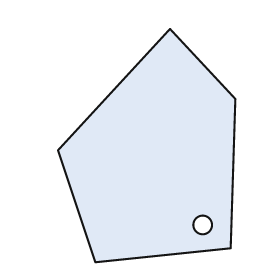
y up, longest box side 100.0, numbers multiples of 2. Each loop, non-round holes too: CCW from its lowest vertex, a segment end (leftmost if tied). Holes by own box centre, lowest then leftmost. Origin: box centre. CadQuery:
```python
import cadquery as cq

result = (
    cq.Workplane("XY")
    .moveTo(-22.0, -50.0)
    .lineTo(36.0, -44.0)
    .lineTo(38.0, 20.0)
    .lineTo(10.0, 50.0)
    .lineTo(-38.0, -2.0)
    .close()
    .moveTo(24.0, -34.0)
    .circle(4.0)
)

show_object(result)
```